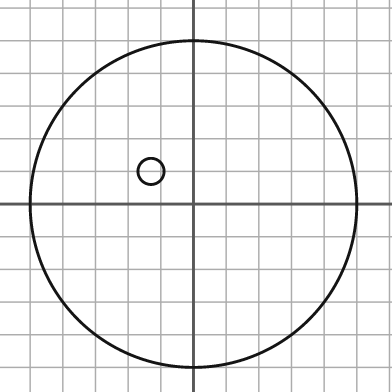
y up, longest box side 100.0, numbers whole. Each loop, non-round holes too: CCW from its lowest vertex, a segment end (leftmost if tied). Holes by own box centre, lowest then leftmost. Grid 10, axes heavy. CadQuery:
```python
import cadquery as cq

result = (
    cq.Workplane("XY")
    .moveTo(0.0, 0.0)
    .circle(50.0)
    .moveTo(-13.0, 10.0)
    .circle(4.0)
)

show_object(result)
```